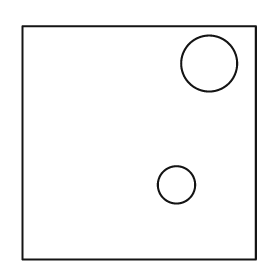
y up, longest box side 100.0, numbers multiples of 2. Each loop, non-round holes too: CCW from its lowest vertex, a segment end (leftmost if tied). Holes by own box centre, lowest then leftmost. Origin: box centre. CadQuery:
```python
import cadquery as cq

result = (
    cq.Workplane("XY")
    .moveTo(-50.0, -50.0)
    .lineTo(50.0, -50.0)
    .lineTo(50.0, 50.0)
    .lineTo(-50.0, 50.0)
    .close()
    .moveTo(16.0, -18.0)
    .circle(8.0)
    .moveTo(30.0, 34.0)
    .circle(12.0)
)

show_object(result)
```